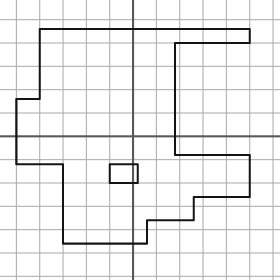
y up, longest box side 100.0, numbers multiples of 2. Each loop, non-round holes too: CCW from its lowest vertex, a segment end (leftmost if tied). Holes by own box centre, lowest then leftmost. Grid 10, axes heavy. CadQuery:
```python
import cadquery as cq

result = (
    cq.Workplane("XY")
    .moveTo(-30.0, -46.0)
    .lineTo(6.0, -46.0)
    .lineTo(6.0, -36.0)
    .lineTo(26.0, -36.0)
    .lineTo(26.0, -26.0)
    .lineTo(50.0, -26.0)
    .lineTo(50.0, -8.0)
    .lineTo(18.0, -8.0)
    .lineTo(18.0, 40.0)
    .lineTo(50.0, 40.0)
    .lineTo(50.0, 46.0)
    .lineTo(-40.0, 46.0)
    .lineTo(-40.0, 16.0)
    .lineTo(-50.0, 16.0)
    .lineTo(-50.0, -12.0)
    .lineTo(-30.0, -12.0)
    .close()
    .moveTo(-10.0, -20.0)
    .lineTo(2.0, -20.0)
    .lineTo(2.0, -12.0)
    .lineTo(-10.0, -12.0)
    .close()
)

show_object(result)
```